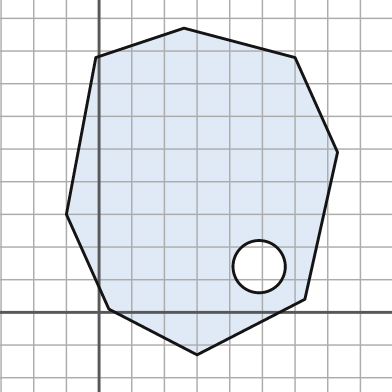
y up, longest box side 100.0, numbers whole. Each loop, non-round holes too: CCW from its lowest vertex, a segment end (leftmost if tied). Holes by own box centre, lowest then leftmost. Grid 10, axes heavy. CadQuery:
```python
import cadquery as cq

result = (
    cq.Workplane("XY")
    .moveTo(30.0, -13.0)
    .lineTo(63.0, 4.0)
    .lineTo(73.0, 49.0)
    .lineTo(60.0, 78.0)
    .lineTo(26.0, 87.0)
    .lineTo(-1.0, 78.0)
    .lineTo(-10.0, 30.0)
    .lineTo(3.0, 1.0)
    .close()
    .moveTo(49.0, 14.0)
    .circle(8.0)
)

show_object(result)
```